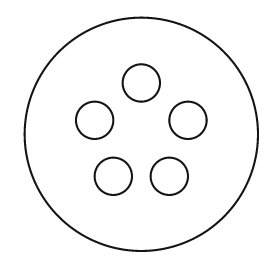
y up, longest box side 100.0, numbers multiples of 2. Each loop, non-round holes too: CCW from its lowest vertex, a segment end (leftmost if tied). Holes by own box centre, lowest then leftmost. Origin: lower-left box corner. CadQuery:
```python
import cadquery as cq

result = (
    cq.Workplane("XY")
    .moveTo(50.0, 50.0)
    .circle(50.0)
    .moveTo(38.0, 32.0)
    .circle(8.0)
    .moveTo(62.0, 32.0)
    .circle(8.0)
    .moveTo(30.0, 56.0)
    .circle(8.0)
    .moveTo(70.0, 56.0)
    .circle(8.0)
    .moveTo(50.0, 72.0)
    .circle(8.0)
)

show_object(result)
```